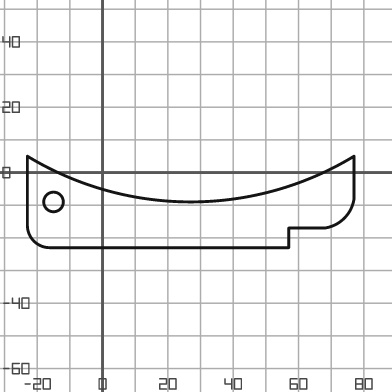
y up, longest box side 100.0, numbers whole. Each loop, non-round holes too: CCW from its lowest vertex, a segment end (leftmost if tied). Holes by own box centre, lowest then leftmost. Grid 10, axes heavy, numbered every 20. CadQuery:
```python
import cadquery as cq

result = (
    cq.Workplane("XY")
    .moveTo(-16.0, -23.0)
    .lineTo(57.0, -23.0)
    .lineTo(57.0, -17.0)
    .lineTo(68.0, -17.0)
    .threePointArc((74.0, -14.0), (77.0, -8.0))
    .lineTo(77.0, 5.0)
    .threePointArc((27.0, -9.0), (-23.0, 5.0))
    .lineTo(-23.0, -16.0)
    .threePointArc((-21.0, -21.0), (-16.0, -23.0))
    .close()
    .moveTo(-15.0, -9.0)
    .circle(3.0)
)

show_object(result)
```